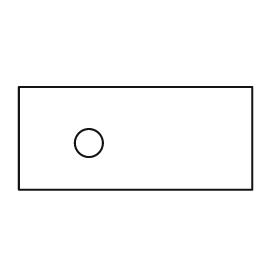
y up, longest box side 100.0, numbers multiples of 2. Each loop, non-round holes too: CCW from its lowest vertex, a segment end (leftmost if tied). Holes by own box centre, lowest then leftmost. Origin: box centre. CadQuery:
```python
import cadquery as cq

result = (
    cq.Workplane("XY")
    .moveTo(-50.0, -22.0)
    .lineTo(50.0, -22.0)
    .lineTo(50.0, 22.0)
    .lineTo(-50.0, 22.0)
    .close()
    .moveTo(-20.0, -2.0)
    .circle(6.0)
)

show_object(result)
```